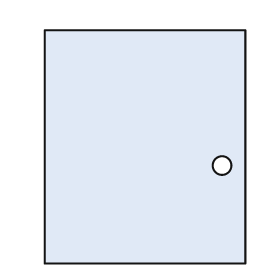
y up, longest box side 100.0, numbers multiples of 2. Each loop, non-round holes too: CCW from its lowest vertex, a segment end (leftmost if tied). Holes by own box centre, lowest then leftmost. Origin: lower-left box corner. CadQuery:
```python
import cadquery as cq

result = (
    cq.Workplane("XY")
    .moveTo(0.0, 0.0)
    .lineTo(86.0, 0.0)
    .lineTo(86.0, 100.0)
    .lineTo(0.0, 100.0)
    .close()
    .moveTo(76.0, 42.0)
    .circle(4.0)
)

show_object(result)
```